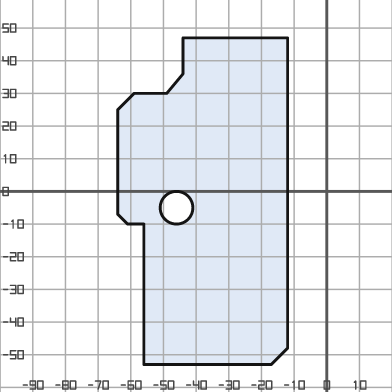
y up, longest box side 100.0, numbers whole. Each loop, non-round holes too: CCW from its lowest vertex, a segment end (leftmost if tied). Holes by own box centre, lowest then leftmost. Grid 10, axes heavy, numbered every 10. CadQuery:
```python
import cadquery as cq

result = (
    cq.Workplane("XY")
    .moveTo(-56.0, -53.0)
    .lineTo(-17.0, -53.0)
    .lineTo(-12.0, -48.0)
    .lineTo(-12.0, 47.0)
    .lineTo(-44.0, 47.0)
    .lineTo(-44.0, 36.0)
    .lineTo(-49.0, 30.0)
    .lineTo(-59.0, 30.0)
    .lineTo(-64.0, 25.0)
    .lineTo(-64.0, -7.0)
    .lineTo(-61.0, -10.0)
    .lineTo(-56.0, -10.0)
    .close()
    .moveTo(-46.0, -5.0)
    .circle(5.0)
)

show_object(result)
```